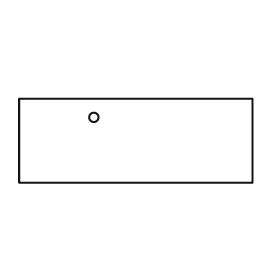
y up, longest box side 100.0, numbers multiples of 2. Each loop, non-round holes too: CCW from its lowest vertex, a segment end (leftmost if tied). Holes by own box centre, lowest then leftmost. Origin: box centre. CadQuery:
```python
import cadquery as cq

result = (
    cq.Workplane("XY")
    .moveTo(-50.0, -18.0)
    .lineTo(50.0, -18.0)
    .lineTo(50.0, 18.0)
    .lineTo(-50.0, 18.0)
    .close()
    .moveTo(-18.0, 10.0)
    .circle(2.0)
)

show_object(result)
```